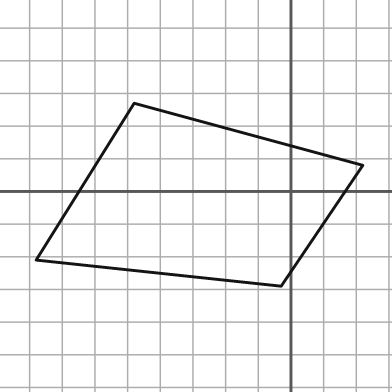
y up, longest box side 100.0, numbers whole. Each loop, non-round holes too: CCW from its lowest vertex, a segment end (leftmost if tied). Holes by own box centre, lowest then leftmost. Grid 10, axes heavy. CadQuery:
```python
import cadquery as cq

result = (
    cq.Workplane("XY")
    .moveTo(-3.0, -29.0)
    .lineTo(22.0, 8.0)
    .lineTo(-48.0, 27.0)
    .lineTo(-78.0, -21.0)
    .close()
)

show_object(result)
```